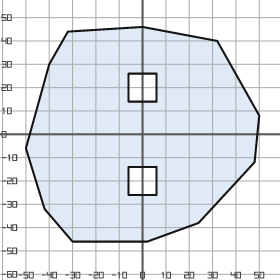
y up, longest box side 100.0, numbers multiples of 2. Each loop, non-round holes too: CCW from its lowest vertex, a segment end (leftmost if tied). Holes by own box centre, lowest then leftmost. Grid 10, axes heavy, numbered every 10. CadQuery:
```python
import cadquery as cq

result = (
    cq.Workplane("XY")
    .moveTo(-30.0, -46.0)
    .lineTo(2.0, -46.0)
    .lineTo(24.0, -38.0)
    .lineTo(48.0, -12.0)
    .lineTo(50.0, 8.0)
    .lineTo(32.0, 40.0)
    .lineTo(0.0, 46.0)
    .lineTo(-32.0, 44.0)
    .lineTo(-40.0, 30.0)
    .lineTo(-50.0, -6.0)
    .lineTo(-42.0, -32.0)
    .close()
    .moveTo(-6.0, -26.0)
    .lineTo(6.0, -26.0)
    .lineTo(6.0, -14.0)
    .lineTo(-6.0, -14.0)
    .close()
    .moveTo(-6.0, 14.0)
    .lineTo(6.0, 14.0)
    .lineTo(6.0, 26.0)
    .lineTo(-6.0, 26.0)
    .close()
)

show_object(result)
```